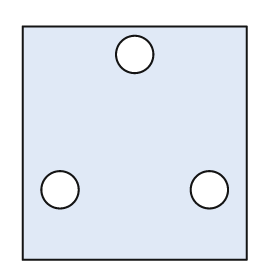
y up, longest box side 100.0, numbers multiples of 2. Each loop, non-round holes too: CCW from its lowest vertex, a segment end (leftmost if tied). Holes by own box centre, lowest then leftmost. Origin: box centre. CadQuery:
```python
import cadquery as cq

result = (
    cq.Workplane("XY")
    .moveTo(-48.0, -50.0)
    .lineTo(48.0, -50.0)
    .lineTo(48.0, 50.0)
    .lineTo(-48.0, 50.0)
    .close()
    .moveTo(-32.0, -20.0)
    .circle(8.0)
    .moveTo(32.0, -20.0)
    .circle(8.0)
    .moveTo(0.0, 38.0)
    .circle(8.0)
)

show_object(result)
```